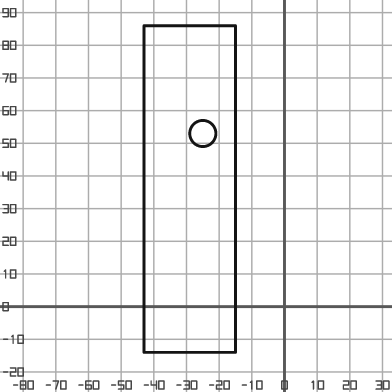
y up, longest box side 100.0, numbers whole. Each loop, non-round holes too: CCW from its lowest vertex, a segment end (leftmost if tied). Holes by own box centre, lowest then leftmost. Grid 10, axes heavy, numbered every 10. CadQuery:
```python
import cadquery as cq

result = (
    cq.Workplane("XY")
    .moveTo(-43.0, -14.0)
    .lineTo(-15.0, -14.0)
    .lineTo(-15.0, 86.0)
    .lineTo(-43.0, 86.0)
    .close()
    .moveTo(-25.0, 53.0)
    .circle(4.0)
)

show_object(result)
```